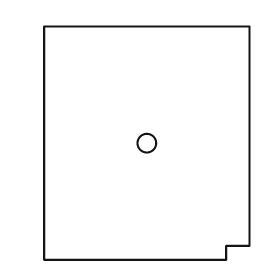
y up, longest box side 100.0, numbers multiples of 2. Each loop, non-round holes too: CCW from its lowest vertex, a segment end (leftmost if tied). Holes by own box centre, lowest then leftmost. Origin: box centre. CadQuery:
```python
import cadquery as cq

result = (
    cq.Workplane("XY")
    .moveTo(-44.0, -50.0)
    .lineTo(34.0, -50.0)
    .lineTo(34.0, -44.0)
    .lineTo(44.0, -44.0)
    .lineTo(44.0, 50.0)
    .lineTo(-44.0, 50.0)
    .close()
    .moveTo(0.0, 0.0)
    .circle(4.0)
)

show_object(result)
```